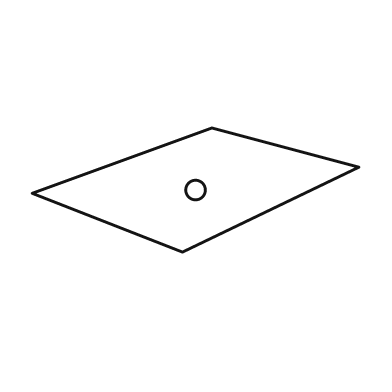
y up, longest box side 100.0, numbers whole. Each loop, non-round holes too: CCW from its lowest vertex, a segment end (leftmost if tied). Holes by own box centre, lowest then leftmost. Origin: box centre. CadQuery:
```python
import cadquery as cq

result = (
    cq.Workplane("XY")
    .moveTo(-4.0, -19.0)
    .lineTo(50.0, 7.0)
    .lineTo(5.0, 19.0)
    .lineTo(-50.0, -1.0)
    .close()
    .moveTo(0.0, 0.0)
    .circle(3.0)
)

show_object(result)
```